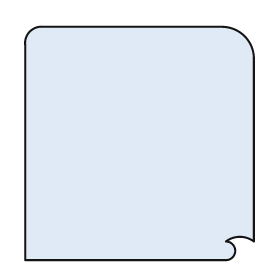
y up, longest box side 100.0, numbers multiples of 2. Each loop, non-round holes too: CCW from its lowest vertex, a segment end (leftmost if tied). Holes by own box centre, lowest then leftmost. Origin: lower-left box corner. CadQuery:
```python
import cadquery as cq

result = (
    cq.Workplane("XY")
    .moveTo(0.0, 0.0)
    .lineTo(86.0, 0.0)
    .threePointArc((90.0, 4.0), (86.0, 8.0))
    .threePointArc((92.0, 10.0), (98.0, 8.0))
    .lineTo(98.0, 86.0)
    .threePointArc((94.0, 96.0), (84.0, 100.0))
    .lineTo(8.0, 100.0)
    .threePointArc((2.0, 98.0), (0.0, 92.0))
    .close()
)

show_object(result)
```